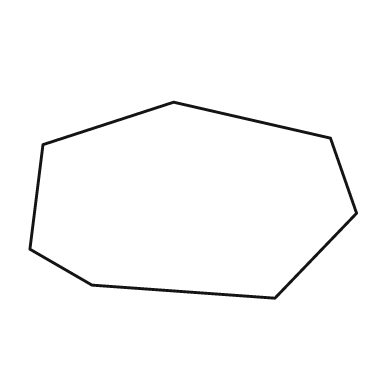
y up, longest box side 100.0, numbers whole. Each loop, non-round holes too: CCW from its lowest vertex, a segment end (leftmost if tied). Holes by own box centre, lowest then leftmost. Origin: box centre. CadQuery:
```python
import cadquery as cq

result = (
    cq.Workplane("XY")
    .moveTo(25.0, -30.0)
    .lineTo(50.0, -4.0)
    .lineTo(42.0, 19.0)
    .lineTo(-6.0, 30.0)
    .lineTo(-46.0, 17.0)
    .lineTo(-50.0, -15.0)
    .lineTo(-31.0, -26.0)
    .close()
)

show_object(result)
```